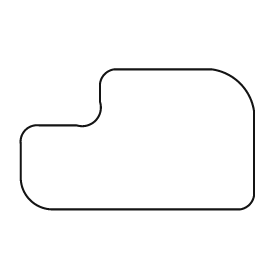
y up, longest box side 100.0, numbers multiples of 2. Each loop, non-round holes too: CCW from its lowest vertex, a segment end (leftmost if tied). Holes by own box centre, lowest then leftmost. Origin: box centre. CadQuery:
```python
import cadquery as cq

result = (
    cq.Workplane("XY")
    .moveTo(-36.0, -30.0)
    .lineTo(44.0, -30.0)
    .threePointArc((48.0, -28.0), (50.0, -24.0))
    .lineTo(50.0, 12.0)
    .threePointArc((44.0, 24.0), (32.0, 30.0))
    .lineTo(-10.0, 30.0)
    .threePointArc((-14.0, 28.0), (-16.0, 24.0))
    .lineTo(-16.0, 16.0)
    .threePointArc((-18.0, 8.0), (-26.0, 6.0))
    .lineTo(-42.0, 6.0)
    .threePointArc((-48.0, 4.0), (-50.0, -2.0))
    .lineTo(-50.0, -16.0)
    .threePointArc((-46.0, -26.0), (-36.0, -30.0))
    .close()
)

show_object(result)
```